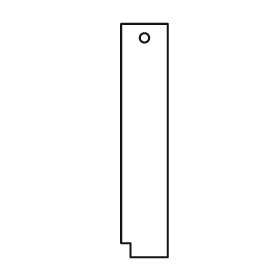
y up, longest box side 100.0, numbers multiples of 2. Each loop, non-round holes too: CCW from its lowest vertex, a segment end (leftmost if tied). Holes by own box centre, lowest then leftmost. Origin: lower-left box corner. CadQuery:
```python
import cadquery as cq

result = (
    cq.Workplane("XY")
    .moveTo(4.0, 0.0)
    .lineTo(20.0, 0.0)
    .lineTo(20.0, 100.0)
    .lineTo(0.0, 100.0)
    .lineTo(0.0, 6.0)
    .lineTo(4.0, 6.0)
    .close()
    .moveTo(10.0, 94.0)
    .circle(2.0)
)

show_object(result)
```